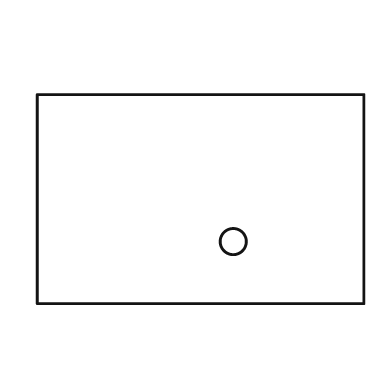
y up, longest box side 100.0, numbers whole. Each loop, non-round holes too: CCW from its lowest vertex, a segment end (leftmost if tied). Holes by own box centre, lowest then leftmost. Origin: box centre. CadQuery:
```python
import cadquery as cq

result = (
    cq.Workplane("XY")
    .moveTo(-50.0, -32.0)
    .lineTo(50.0, -32.0)
    .lineTo(50.0, 32.0)
    .lineTo(-50.0, 32.0)
    .close()
    .moveTo(10.0, -13.0)
    .circle(4.0)
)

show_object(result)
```